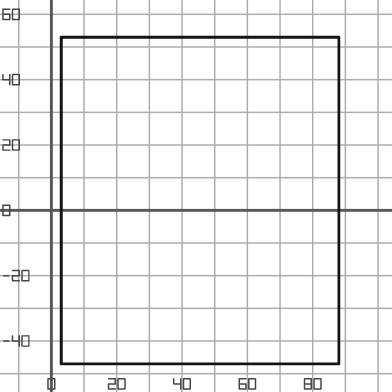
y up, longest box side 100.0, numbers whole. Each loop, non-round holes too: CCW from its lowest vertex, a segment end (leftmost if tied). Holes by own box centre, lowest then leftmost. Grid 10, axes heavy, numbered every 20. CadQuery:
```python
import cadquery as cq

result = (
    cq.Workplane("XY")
    .moveTo(3.0, -47.0)
    .lineTo(88.0, -47.0)
    .lineTo(88.0, 53.0)
    .lineTo(3.0, 53.0)
    .close()
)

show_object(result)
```